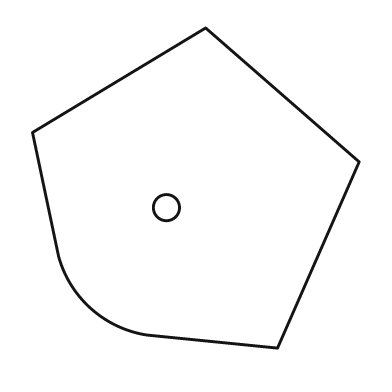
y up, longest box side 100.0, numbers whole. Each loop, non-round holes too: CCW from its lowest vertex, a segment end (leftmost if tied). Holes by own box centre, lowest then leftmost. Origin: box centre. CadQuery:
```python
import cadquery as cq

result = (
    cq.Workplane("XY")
    .moveTo(25.0, -49.0)
    .lineTo(50.0, 8.0)
    .lineTo(3.0, 49.0)
    .lineTo(-50.0, 17.0)
    .lineTo(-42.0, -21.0)
    .threePointArc((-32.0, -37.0), (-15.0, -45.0))
    .close()
    .moveTo(-9.0, -6.0)
    .circle(4.0)
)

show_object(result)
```